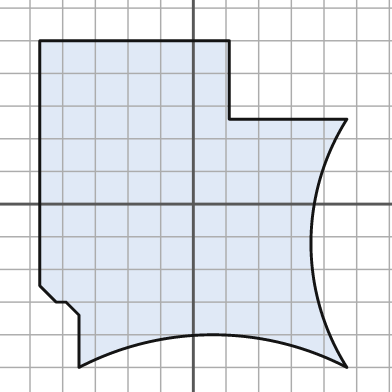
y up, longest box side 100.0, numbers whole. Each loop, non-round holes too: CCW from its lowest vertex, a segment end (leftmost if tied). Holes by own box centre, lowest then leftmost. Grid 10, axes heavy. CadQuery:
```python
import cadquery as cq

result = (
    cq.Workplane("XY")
    .moveTo(-35.0, -50.0)
    .threePointArc((6.0, -40.0), (47.0, -50.0))
    .threePointArc((36.0, -12.0), (47.0, 26.0))
    .lineTo(11.0, 26.0)
    .lineTo(11.0, 50.0)
    .lineTo(-47.0, 50.0)
    .lineTo(-47.0, -25.0)
    .lineTo(-42.0, -30.0)
    .lineTo(-39.0, -30.0)
    .lineTo(-35.0, -34.0)
    .close()
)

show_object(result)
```